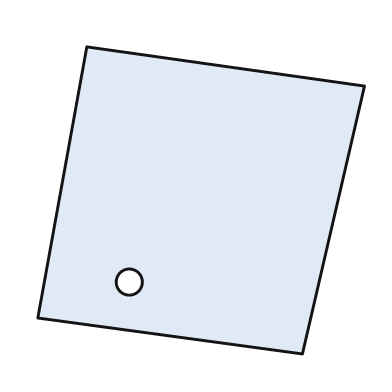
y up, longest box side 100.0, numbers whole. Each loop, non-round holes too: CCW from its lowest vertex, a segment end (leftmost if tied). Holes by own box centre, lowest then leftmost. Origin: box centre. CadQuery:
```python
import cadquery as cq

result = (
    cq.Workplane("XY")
    .moveTo(31.0, -47.0)
    .lineTo(50.0, 35.0)
    .lineTo(-35.0, 47.0)
    .lineTo(-50.0, -36.0)
    .close()
    .moveTo(-22.0, -25.0)
    .circle(4.0)
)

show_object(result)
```